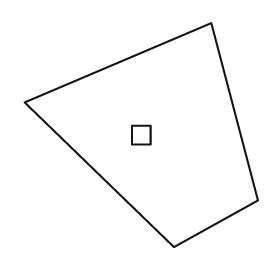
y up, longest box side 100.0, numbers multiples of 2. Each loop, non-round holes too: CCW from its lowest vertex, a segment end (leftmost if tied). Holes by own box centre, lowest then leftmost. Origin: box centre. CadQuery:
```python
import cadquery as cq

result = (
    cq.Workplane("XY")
    .moveTo(14.0, -48.0)
    .lineTo(50.0, -28.0)
    .lineTo(30.0, 48.0)
    .lineTo(-50.0, 14.0)
    .close()
    .moveTo(-4.0, -4.0)
    .lineTo(4.0, -4.0)
    .lineTo(4.0, 4.0)
    .lineTo(-4.0, 4.0)
    .close()
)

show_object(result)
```